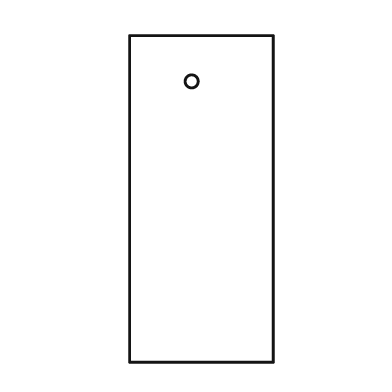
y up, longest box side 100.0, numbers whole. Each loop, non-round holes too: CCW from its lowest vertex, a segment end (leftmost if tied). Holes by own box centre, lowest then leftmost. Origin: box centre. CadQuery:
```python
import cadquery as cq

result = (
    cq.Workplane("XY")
    .moveTo(-22.0, -50.0)
    .lineTo(22.0, -50.0)
    .lineTo(22.0, 50.0)
    .lineTo(-22.0, 50.0)
    .close()
    .moveTo(-3.0, 36.0)
    .circle(2.0)
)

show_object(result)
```